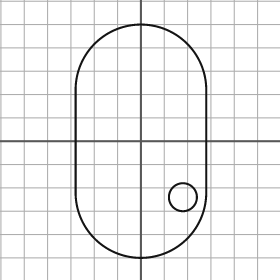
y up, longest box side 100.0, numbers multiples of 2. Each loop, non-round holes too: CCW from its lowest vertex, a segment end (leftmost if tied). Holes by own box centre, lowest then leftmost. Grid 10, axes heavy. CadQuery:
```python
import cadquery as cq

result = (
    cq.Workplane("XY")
    .moveTo(-28.0, -22.0)
    .threePointArc((0.0, -50.0), (28.0, -22.0))
    .lineTo(28.0, 22.0)
    .threePointArc((0.0, 50.0), (-28.0, 22.0))
    .close()
    .moveTo(18.0, -24.0)
    .circle(6.0)
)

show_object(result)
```